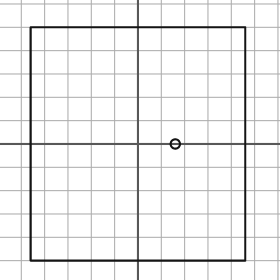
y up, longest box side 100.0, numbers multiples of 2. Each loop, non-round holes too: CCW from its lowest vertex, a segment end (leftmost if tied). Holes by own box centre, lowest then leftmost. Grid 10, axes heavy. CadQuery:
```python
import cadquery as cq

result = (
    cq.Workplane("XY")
    .moveTo(-46.0, -50.0)
    .lineTo(46.0, -50.0)
    .lineTo(46.0, 50.0)
    .lineTo(-46.0, 50.0)
    .close()
    .moveTo(16.0, 0.0)
    .circle(2.0)
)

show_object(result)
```